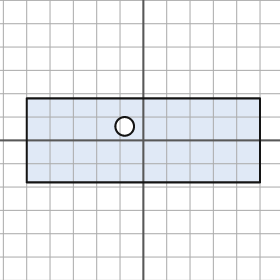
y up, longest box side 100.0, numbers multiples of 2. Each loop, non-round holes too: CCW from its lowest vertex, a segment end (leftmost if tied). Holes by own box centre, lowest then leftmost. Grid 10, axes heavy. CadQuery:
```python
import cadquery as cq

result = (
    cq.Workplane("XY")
    .moveTo(-50.0, -18.0)
    .lineTo(50.0, -18.0)
    .lineTo(50.0, 18.0)
    .lineTo(-50.0, 18.0)
    .close()
    .moveTo(-8.0, 6.0)
    .circle(4.0)
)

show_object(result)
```